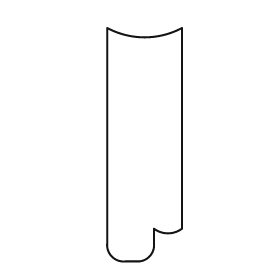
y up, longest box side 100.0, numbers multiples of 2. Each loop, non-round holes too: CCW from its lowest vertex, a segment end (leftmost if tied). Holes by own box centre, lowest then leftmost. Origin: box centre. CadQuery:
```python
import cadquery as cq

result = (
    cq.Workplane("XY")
    .moveTo(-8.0, -50.0)
    .lineTo(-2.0, -50.0)
    .threePointArc((2.0, -48.0), (4.0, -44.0))
    .lineTo(4.0, -36.0)
    .threePointArc((10.0, -38.0), (16.0, -36.0))
    .lineTo(16.0, 50.0)
    .threePointArc((0.0, 46.0), (-16.0, 50.0))
    .lineTo(-16.0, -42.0)
    .threePointArc((-14.0, -48.0), (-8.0, -50.0))
    .close()
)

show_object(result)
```